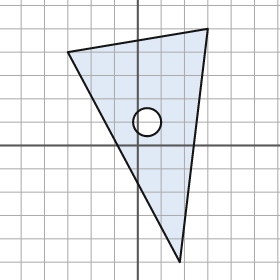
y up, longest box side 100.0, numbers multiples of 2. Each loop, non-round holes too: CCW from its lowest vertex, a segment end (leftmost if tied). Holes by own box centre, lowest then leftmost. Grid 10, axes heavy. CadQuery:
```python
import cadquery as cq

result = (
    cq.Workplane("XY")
    .moveTo(18.0, -50.0)
    .lineTo(30.0, 50.0)
    .lineTo(-30.0, 40.0)
    .close()
    .moveTo(4.0, 10.0)
    .circle(6.0)
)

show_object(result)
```